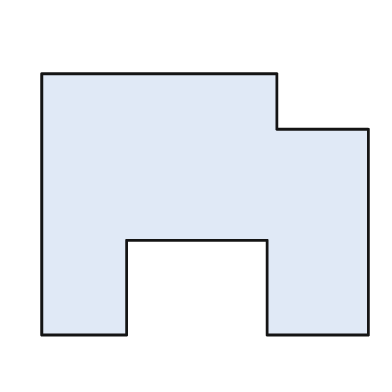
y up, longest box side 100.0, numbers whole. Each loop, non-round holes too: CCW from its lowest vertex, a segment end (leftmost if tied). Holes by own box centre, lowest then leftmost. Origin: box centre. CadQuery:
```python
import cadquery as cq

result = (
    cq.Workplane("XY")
    .moveTo(-50.0, -40.0)
    .lineTo(-24.0, -40.0)
    .lineTo(-24.0, -11.0)
    .lineTo(19.0, -11.0)
    .lineTo(19.0, -40.0)
    .lineTo(50.0, -40.0)
    .lineTo(50.0, 23.0)
    .lineTo(22.0, 23.0)
    .lineTo(22.0, 40.0)
    .lineTo(-50.0, 40.0)
    .close()
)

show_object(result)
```